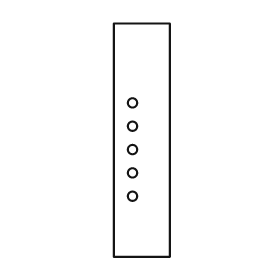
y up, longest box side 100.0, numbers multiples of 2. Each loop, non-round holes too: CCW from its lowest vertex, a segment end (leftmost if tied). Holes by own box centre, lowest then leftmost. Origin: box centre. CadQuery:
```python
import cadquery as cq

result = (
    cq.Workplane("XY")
    .moveTo(-12.0, -50.0)
    .lineTo(12.0, -50.0)
    .lineTo(12.0, 50.0)
    .lineTo(-12.0, 50.0)
    .close()
    .moveTo(-4.0, -24.0)
    .circle(2.0)
    .moveTo(-4.0, -14.0)
    .circle(2.0)
    .moveTo(-4.0, -4.0)
    .circle(2.0)
    .moveTo(-4.0, 6.0)
    .circle(2.0)
    .moveTo(-4.0, 16.0)
    .circle(2.0)
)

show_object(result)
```